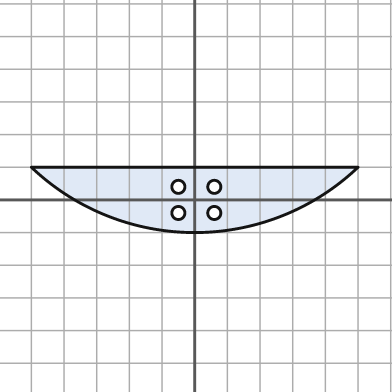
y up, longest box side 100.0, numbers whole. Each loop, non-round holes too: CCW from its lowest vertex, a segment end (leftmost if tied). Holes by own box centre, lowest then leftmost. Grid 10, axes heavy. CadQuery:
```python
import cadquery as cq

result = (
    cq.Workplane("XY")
    .moveTo(-50.0, 10.0)
    .threePointArc((0.0, -10.0), (50.0, 10.0))
    .close()
    .moveTo(-5.0, -4.0)
    .circle(2.0)
    .moveTo(6.0, -4.0)
    .circle(2.0)
    .moveTo(-5.0, 4.0)
    .circle(2.0)
    .moveTo(6.0, 4.0)
    .circle(2.0)
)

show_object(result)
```